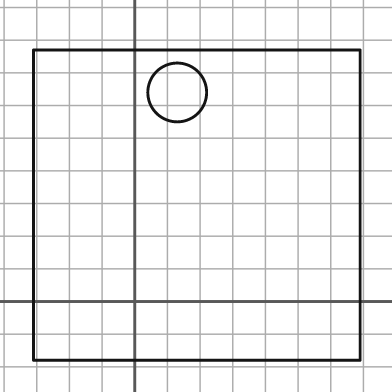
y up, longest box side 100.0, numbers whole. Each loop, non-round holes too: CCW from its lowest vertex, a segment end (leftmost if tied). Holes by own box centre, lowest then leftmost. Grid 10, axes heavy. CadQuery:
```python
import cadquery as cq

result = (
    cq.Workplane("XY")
    .moveTo(-31.0, -18.0)
    .lineTo(69.0, -18.0)
    .lineTo(69.0, 77.0)
    .lineTo(-31.0, 77.0)
    .close()
    .moveTo(13.0, 64.0)
    .circle(9.0)
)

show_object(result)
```